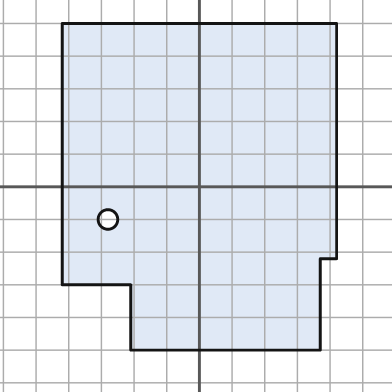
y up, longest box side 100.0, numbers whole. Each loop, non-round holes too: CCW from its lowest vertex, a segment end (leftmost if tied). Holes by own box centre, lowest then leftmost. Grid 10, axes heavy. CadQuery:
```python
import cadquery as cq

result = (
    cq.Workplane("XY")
    .moveTo(-21.0, -50.0)
    .lineTo(37.0, -50.0)
    .lineTo(37.0, -22.0)
    .lineTo(42.0, -22.0)
    .lineTo(42.0, 50.0)
    .lineTo(-42.0, 50.0)
    .lineTo(-42.0, -30.0)
    .lineTo(-21.0, -30.0)
    .close()
    .moveTo(-28.0, -10.0)
    .circle(3.0)
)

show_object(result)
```